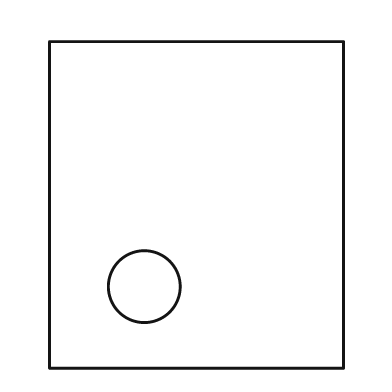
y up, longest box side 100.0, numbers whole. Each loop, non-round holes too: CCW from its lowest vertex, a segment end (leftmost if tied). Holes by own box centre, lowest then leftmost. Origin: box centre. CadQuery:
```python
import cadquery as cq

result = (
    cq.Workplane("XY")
    .moveTo(-45.0, -50.0)
    .lineTo(45.0, -50.0)
    .lineTo(45.0, 50.0)
    .lineTo(-45.0, 50.0)
    .close()
    .moveTo(-16.0, -25.0)
    .circle(11.0)
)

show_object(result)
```